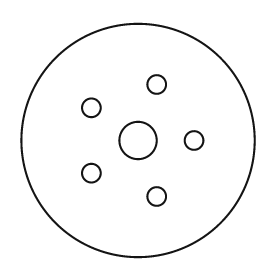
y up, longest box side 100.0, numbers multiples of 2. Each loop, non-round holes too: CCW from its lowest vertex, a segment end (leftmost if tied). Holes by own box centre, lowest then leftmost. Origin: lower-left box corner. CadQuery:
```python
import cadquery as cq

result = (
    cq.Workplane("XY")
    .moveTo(50.0, 50.0)
    .circle(50.0)
    .moveTo(58.0, 26.0)
    .circle(4.0)
    .moveTo(30.0, 36.0)
    .circle(4.0)
    .moveTo(50.0, 50.0)
    .circle(8.0)
    .moveTo(74.0, 50.0)
    .circle(4.0)
    .moveTo(30.0, 64.0)
    .circle(4.0)
    .moveTo(58.0, 74.0)
    .circle(4.0)
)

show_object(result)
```